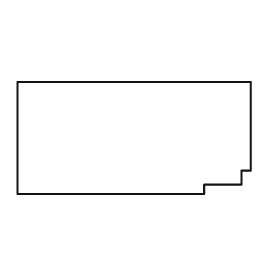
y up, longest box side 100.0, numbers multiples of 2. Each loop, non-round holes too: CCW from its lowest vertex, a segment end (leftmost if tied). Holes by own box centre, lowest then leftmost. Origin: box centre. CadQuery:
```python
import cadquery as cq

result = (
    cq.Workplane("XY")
    .moveTo(-50.0, -24.0)
    .lineTo(30.0, -24.0)
    .lineTo(30.0, -20.0)
    .lineTo(46.0, -20.0)
    .lineTo(46.0, -14.0)
    .lineTo(50.0, -14.0)
    .lineTo(50.0, 24.0)
    .lineTo(-50.0, 24.0)
    .close()
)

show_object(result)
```